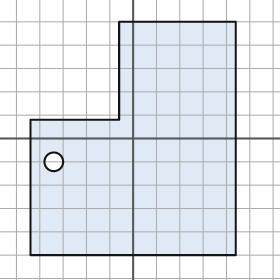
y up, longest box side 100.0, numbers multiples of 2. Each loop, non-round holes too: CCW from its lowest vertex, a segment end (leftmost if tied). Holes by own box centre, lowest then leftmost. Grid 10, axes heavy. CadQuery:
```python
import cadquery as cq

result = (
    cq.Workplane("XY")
    .moveTo(-44.0, -50.0)
    .lineTo(44.0, -50.0)
    .lineTo(44.0, 50.0)
    .lineTo(-6.0, 50.0)
    .lineTo(-6.0, 8.0)
    .lineTo(-44.0, 8.0)
    .close()
    .moveTo(-34.0, -10.0)
    .circle(4.0)
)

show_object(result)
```